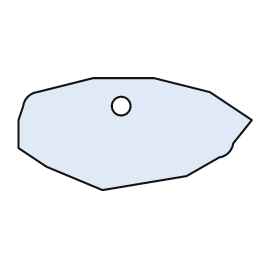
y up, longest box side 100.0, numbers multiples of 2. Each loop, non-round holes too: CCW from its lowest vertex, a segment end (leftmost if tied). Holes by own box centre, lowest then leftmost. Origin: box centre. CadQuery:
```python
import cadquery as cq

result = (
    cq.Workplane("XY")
    .moveTo(-14.0, -24.0)
    .lineTo(22.0, -18.0)
    .lineTo(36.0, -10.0)
    .threePointArc((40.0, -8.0), (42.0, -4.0))
    .lineTo(50.0, 6.0)
    .lineTo(32.0, 18.0)
    .lineTo(8.0, 24.0)
    .lineTo(-18.0, 24.0)
    .lineTo(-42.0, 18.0)
    .threePointArc((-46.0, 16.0), (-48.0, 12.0))
    .lineTo(-50.0, 6.0)
    .lineTo(-50.0, -6.0)
    .lineTo(-38.0, -14.0)
    .close()
    .moveTo(-6.0, 12.0)
    .circle(4.0)
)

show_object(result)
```